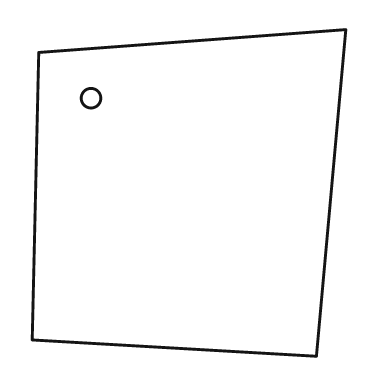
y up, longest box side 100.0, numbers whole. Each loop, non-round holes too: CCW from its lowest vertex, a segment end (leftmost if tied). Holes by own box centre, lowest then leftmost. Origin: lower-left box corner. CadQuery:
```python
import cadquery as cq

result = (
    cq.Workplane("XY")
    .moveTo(87.0, 0.0)
    .lineTo(96.0, 100.0)
    .lineTo(2.0, 93.0)
    .lineTo(0.0, 5.0)
    .close()
    .moveTo(18.0, 79.0)
    .circle(3.0)
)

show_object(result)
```